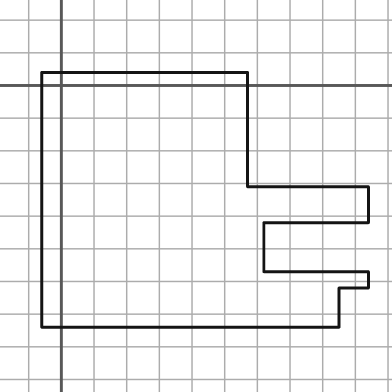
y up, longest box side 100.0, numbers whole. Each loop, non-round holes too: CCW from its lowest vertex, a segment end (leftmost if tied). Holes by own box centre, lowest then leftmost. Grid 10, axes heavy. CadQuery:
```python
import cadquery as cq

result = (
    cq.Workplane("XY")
    .moveTo(-6.0, -74.0)
    .lineTo(85.0, -74.0)
    .lineTo(85.0, -62.0)
    .lineTo(94.0, -62.0)
    .lineTo(94.0, -57.0)
    .lineTo(62.0, -57.0)
    .lineTo(62.0, -42.0)
    .lineTo(94.0, -42.0)
    .lineTo(94.0, -31.0)
    .lineTo(57.0, -31.0)
    .lineTo(57.0, 4.0)
    .lineTo(-6.0, 4.0)
    .close()
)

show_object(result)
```